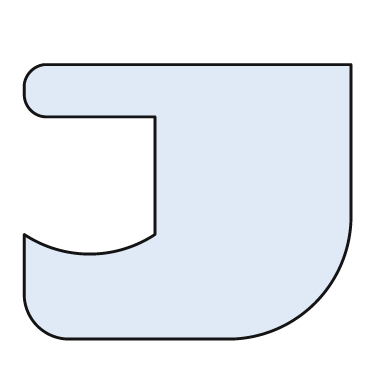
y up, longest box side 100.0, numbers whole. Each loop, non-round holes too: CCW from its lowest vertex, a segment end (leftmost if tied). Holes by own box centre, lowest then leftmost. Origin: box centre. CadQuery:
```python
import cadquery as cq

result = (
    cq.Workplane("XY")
    .moveTo(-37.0, -42.0)
    .lineTo(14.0, -42.0)
    .threePointArc((39.0, -31.0), (50.0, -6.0))
    .lineTo(50.0, 42.0)
    .lineTo(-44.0, 42.0)
    .threePointArc((-48.0, 40.0), (-50.0, 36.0))
    .lineTo(-50.0, 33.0)
    .threePointArc((-48.0, 28.0), (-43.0, 26.0))
    .lineTo(-10.0, 26.0)
    .lineTo(-10.0, -10.0)
    .threePointArc((-30.0, -16.0), (-50.0, -10.0))
    .lineTo(-50.0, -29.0)
    .threePointArc((-46.0, -38.0), (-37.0, -42.0))
    .close()
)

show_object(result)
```